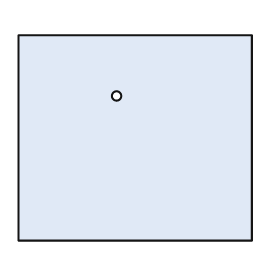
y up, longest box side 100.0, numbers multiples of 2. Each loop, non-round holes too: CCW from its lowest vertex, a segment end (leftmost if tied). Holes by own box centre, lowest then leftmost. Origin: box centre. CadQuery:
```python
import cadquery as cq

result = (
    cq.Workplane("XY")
    .moveTo(-50.0, -44.0)
    .lineTo(50.0, -44.0)
    .lineTo(50.0, 44.0)
    .lineTo(-50.0, 44.0)
    .close()
    .moveTo(-8.0, 18.0)
    .circle(2.0)
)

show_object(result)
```